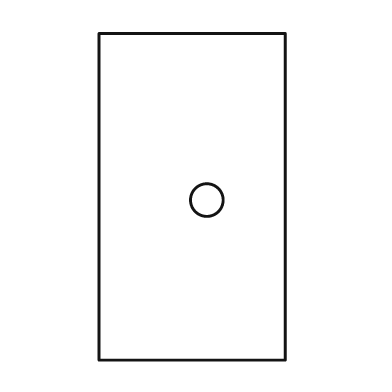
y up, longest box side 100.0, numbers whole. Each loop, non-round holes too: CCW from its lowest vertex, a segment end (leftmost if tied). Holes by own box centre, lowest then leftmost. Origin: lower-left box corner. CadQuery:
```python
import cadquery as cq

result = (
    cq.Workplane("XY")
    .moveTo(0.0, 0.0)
    .lineTo(57.0, 0.0)
    .lineTo(57.0, 100.0)
    .lineTo(0.0, 100.0)
    .close()
    .moveTo(33.0, 49.0)
    .circle(5.0)
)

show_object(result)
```